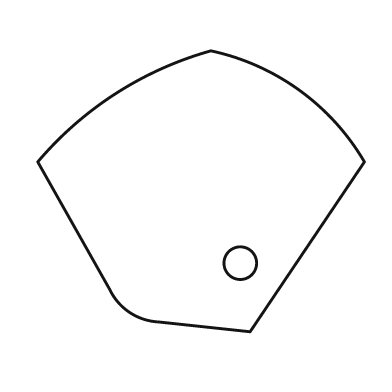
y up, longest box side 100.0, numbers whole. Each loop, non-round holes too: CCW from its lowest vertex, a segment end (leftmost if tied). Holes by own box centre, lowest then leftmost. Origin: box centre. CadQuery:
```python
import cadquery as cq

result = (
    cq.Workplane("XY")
    .moveTo(15.0, -43.0)
    .lineTo(50.0, 9.0)
    .threePointArc((30.0, 31.0), (3.0, 43.0))
    .threePointArc((-26.0, 30.0), (-50.0, 9.0))
    .lineTo(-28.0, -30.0)
    .threePointArc((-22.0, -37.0), (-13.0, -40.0))
    .close()
    .moveTo(12.0, -22.0)
    .circle(5.0)
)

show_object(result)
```